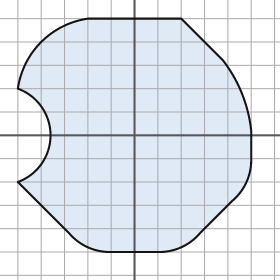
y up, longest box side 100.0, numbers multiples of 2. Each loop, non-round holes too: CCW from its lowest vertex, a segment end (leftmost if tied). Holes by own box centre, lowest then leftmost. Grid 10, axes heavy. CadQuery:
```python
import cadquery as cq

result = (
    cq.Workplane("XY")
    .moveTo(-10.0, -50.0)
    .lineTo(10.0, -50.0)
    .threePointArc((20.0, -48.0), (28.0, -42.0))
    .lineTo(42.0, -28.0)
    .threePointArc((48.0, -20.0), (50.0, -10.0))
    .lineTo(50.0, 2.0)
    .threePointArc((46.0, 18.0), (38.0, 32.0))
    .lineTo(20.0, 50.0)
    .lineTo(-20.0, 50.0)
    .threePointArc((-40.0, 40.0), (-50.0, 20.0))
    .threePointArc((-36.0, 0.0), (-50.0, -20.0))
    .lineTo(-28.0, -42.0)
    .threePointArc((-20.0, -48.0), (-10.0, -50.0))
    .close()
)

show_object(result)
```